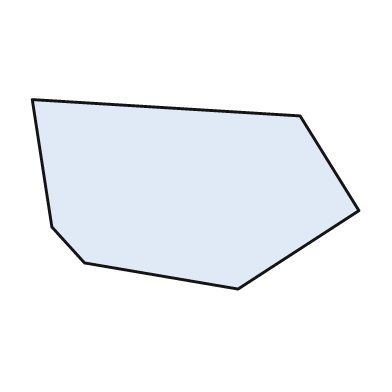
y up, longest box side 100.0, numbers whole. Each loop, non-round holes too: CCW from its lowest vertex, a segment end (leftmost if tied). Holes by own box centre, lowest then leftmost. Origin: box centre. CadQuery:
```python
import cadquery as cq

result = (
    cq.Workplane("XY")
    .moveTo(13.0, -29.0)
    .lineTo(50.0, -5.0)
    .lineTo(32.0, 24.0)
    .lineTo(-50.0, 29.0)
    .lineTo(-44.0, -10.0)
    .lineTo(-34.0, -21.0)
    .close()
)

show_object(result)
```